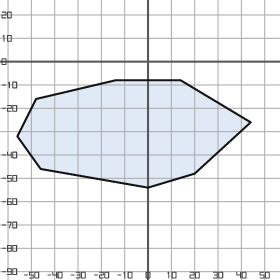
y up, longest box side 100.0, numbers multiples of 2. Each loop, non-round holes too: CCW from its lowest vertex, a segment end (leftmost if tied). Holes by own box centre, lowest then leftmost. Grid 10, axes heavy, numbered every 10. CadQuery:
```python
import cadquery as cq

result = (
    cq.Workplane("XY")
    .moveTo(0.0, -54.0)
    .lineTo(20.0, -48.0)
    .lineTo(44.0, -26.0)
    .lineTo(14.0, -8.0)
    .lineTo(-14.0, -8.0)
    .lineTo(-48.0, -16.0)
    .lineTo(-56.0, -32.0)
    .lineTo(-46.0, -46.0)
    .close()
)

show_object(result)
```